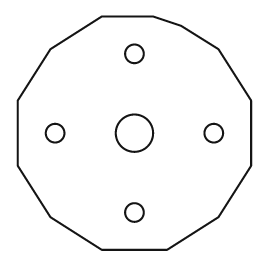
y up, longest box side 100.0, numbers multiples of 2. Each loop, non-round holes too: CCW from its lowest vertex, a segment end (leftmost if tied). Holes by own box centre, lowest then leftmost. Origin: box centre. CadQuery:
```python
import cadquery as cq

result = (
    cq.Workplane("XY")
    .moveTo(-14.0, -50.0)
    .lineTo(14.0, -50.0)
    .lineTo(36.0, -36.0)
    .lineTo(50.0, -14.0)
    .lineTo(50.0, 14.0)
    .lineTo(36.0, 36.0)
    .lineTo(20.0, 46.0)
    .lineTo(8.0, 50.0)
    .lineTo(-14.0, 50.0)
    .lineTo(-36.0, 36.0)
    .lineTo(-50.0, 14.0)
    .lineTo(-50.0, -14.0)
    .lineTo(-36.0, -36.0)
    .close()
    .moveTo(0.0, -34.0)
    .circle(4.0)
    .moveTo(-34.0, 0.0)
    .circle(4.0)
    .moveTo(0.0, 0.0)
    .circle(8.0)
    .moveTo(34.0, 0.0)
    .circle(4.0)
    .moveTo(0.0, 34.0)
    .circle(4.0)
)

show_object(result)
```